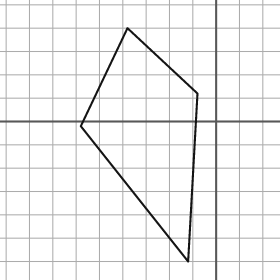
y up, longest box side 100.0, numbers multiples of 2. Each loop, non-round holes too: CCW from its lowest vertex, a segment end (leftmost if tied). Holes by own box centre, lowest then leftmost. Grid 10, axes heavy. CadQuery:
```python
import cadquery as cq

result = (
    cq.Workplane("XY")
    .moveTo(-12.0, -60.0)
    .lineTo(-8.0, 12.0)
    .lineTo(-38.0, 40.0)
    .lineTo(-58.0, -2.0)
    .close()
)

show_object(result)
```